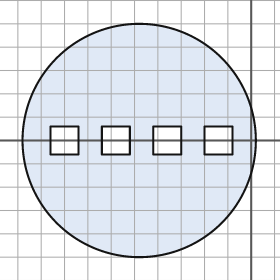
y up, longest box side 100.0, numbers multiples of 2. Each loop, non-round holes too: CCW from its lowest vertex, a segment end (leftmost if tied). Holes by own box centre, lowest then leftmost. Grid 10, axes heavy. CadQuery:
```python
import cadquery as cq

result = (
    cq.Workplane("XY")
    .moveTo(-48.0, 0.0)
    .circle(50.0)
    .moveTo(-86.0, -6.0)
    .lineTo(-74.0, -6.0)
    .lineTo(-74.0, 6.0)
    .lineTo(-86.0, 6.0)
    .close()
    .moveTo(-64.0, -6.0)
    .lineTo(-52.0, -6.0)
    .lineTo(-52.0, 6.0)
    .lineTo(-64.0, 6.0)
    .close()
    .moveTo(-42.0, -6.0)
    .lineTo(-30.0, -6.0)
    .lineTo(-30.0, 6.0)
    .lineTo(-42.0, 6.0)
    .close()
    .moveTo(-20.0, -6.0)
    .lineTo(-8.0, -6.0)
    .lineTo(-8.0, 6.0)
    .lineTo(-20.0, 6.0)
    .close()
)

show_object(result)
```